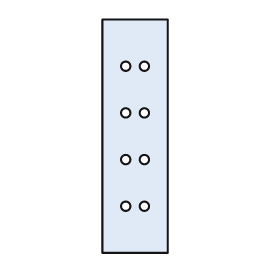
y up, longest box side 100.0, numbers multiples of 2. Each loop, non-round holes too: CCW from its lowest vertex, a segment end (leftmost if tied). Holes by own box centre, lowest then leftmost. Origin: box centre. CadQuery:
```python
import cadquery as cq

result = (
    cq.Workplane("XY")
    .moveTo(-14.0, -50.0)
    .lineTo(14.0, -50.0)
    .lineTo(14.0, 50.0)
    .lineTo(-14.0, 50.0)
    .close()
    .moveTo(-4.0, -30.0)
    .circle(2.0)
    .moveTo(4.0, -30.0)
    .circle(2.0)
    .moveTo(-4.0, -10.0)
    .circle(2.0)
    .moveTo(4.0, -10.0)
    .circle(2.0)
    .moveTo(-4.0, 10.0)
    .circle(2.0)
    .moveTo(4.0, 10.0)
    .circle(2.0)
    .moveTo(-4.0, 30.0)
    .circle(2.0)
    .moveTo(4.0, 30.0)
    .circle(2.0)
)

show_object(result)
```